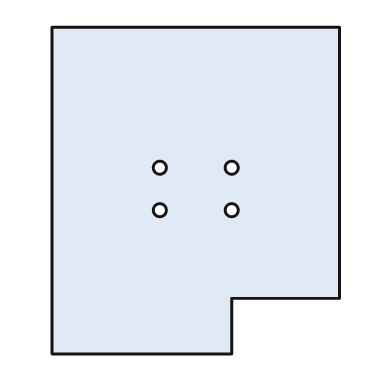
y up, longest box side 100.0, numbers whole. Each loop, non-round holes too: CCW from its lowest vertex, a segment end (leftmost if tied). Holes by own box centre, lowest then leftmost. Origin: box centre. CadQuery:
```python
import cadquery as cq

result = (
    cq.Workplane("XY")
    .moveTo(-44.0, -50.0)
    .lineTo(11.0, -50.0)
    .lineTo(11.0, -33.0)
    .lineTo(44.0, -33.0)
    .lineTo(44.0, 50.0)
    .lineTo(-44.0, 50.0)
    .close()
    .moveTo(-11.0, -6.0)
    .circle(2.0)
    .moveTo(11.0, -6.0)
    .circle(2.0)
    .moveTo(-11.0, 7.0)
    .circle(2.0)
    .moveTo(11.0, 7.0)
    .circle(2.0)
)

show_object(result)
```